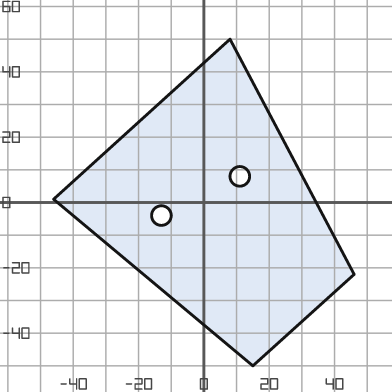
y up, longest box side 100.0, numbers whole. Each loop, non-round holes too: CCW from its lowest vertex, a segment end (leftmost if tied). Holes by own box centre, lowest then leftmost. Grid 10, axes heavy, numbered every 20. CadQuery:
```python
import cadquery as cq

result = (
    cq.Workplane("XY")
    .moveTo(15.0, -50.0)
    .lineTo(46.0, -22.0)
    .lineTo(8.0, 50.0)
    .lineTo(-46.0, 1.0)
    .close()
    .moveTo(-13.0, -4.0)
    .circle(3.0)
    .moveTo(11.0, 8.0)
    .circle(3.0)
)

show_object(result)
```